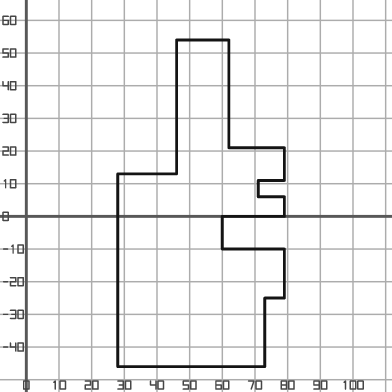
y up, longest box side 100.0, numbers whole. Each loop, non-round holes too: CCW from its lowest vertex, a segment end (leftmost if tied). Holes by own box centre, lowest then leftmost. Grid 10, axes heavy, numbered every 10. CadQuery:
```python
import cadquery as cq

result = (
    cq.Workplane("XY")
    .moveTo(28.0, -46.0)
    .lineTo(73.0, -46.0)
    .lineTo(73.0, -25.0)
    .lineTo(79.0, -25.0)
    .lineTo(79.0, -10.0)
    .lineTo(60.0, -10.0)
    .lineTo(60.0, 0.0)
    .lineTo(79.0, 0.0)
    .lineTo(79.0, 6.0)
    .lineTo(71.0, 6.0)
    .lineTo(71.0, 11.0)
    .lineTo(79.0, 11.0)
    .lineTo(79.0, 21.0)
    .lineTo(62.0, 21.0)
    .lineTo(62.0, 54.0)
    .lineTo(46.0, 54.0)
    .lineTo(46.0, 13.0)
    .lineTo(28.0, 13.0)
    .close()
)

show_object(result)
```